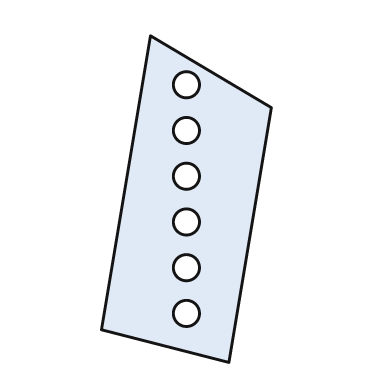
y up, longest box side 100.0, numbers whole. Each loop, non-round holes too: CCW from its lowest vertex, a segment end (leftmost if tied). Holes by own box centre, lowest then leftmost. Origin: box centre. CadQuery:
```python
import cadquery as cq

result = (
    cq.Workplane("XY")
    .moveTo(13.0, -50.0)
    .lineTo(26.0, 28.0)
    .lineTo(-11.0, 50.0)
    .lineTo(-26.0, -40.0)
    .close()
    .moveTo(0.0, -35.0)
    .circle(4.0)
    .moveTo(0.0, -21.0)
    .circle(4.0)
    .moveTo(0.0, -7.0)
    .circle(4.0)
    .moveTo(0.0, 7.0)
    .circle(4.0)
    .moveTo(0.0, 21.0)
    .circle(4.0)
    .moveTo(0.0, 35.0)
    .circle(4.0)
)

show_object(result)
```